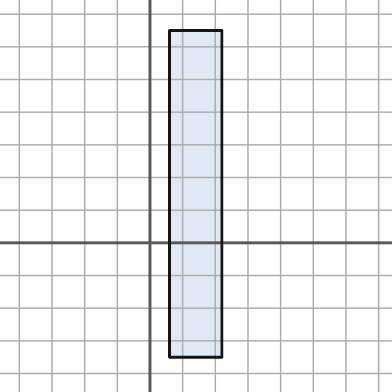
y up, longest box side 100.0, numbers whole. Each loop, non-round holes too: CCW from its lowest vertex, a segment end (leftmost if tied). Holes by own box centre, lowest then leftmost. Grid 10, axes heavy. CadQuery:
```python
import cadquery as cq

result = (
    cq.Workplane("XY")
    .moveTo(6.0, -35.0)
    .lineTo(22.0, -35.0)
    .lineTo(22.0, 65.0)
    .lineTo(6.0, 65.0)
    .close()
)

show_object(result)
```